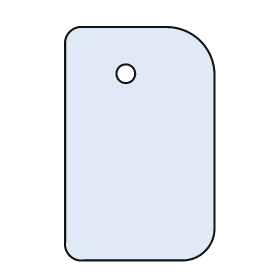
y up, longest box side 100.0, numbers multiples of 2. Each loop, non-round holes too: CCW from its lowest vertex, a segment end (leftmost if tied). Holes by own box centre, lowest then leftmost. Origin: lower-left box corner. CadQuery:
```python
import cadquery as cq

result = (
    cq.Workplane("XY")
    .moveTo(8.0, 0.0)
    .lineTo(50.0, 0.0)
    .threePointArc((60.0, 4.0), (64.0, 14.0))
    .lineTo(64.0, 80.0)
    .threePointArc((58.0, 94.0), (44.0, 100.0))
    .lineTo(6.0, 100.0)
    .threePointArc((2.0, 98.0), (0.0, 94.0))
    .lineTo(0.0, 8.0)
    .threePointArc((2.0, 2.0), (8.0, 0.0))
    .close()
    .moveTo(26.0, 80.0)
    .circle(4.0)
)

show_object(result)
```